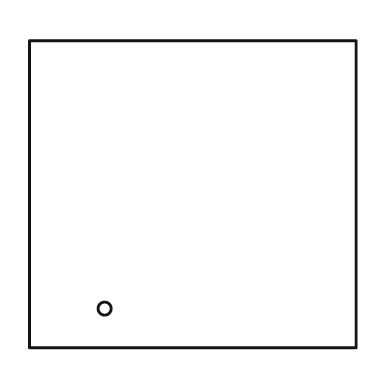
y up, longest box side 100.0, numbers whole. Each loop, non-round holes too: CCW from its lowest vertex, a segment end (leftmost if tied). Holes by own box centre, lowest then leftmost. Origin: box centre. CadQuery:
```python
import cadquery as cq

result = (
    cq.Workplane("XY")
    .moveTo(-50.0, -47.0)
    .lineTo(50.0, -47.0)
    .lineTo(50.0, 47.0)
    .lineTo(-50.0, 47.0)
    .close()
    .moveTo(-27.0, -35.0)
    .circle(2.0)
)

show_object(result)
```